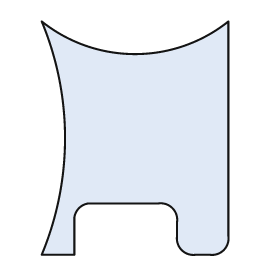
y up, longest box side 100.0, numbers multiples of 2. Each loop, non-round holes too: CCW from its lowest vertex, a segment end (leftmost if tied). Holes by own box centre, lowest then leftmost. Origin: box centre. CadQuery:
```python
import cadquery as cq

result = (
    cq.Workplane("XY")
    .moveTo(-40.0, -50.0)
    .lineTo(-26.0, -50.0)
    .lineTo(-26.0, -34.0)
    .threePointArc((-24.0, -30.0), (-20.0, -28.0))
    .lineTo(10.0, -28.0)
    .threePointArc((16.0, -30.0), (18.0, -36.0))
    .lineTo(18.0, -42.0)
    .threePointArc((20.0, -48.0), (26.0, -50.0))
    .lineTo(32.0, -50.0)
    .threePointArc((38.0, -48.0), (40.0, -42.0))
    .lineTo(40.0, 50.0)
    .threePointArc((0.0, 36.0), (-40.0, 50.0))
    .threePointArc((-30.0, 0.0), (-40.0, -50.0))
    .close()
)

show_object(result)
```